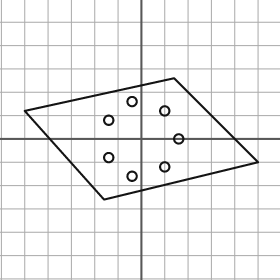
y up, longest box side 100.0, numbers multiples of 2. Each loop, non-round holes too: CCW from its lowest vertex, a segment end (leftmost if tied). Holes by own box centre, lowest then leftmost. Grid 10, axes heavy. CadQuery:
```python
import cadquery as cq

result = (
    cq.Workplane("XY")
    .moveTo(-16.0, -26.0)
    .lineTo(50.0, -10.0)
    .lineTo(14.0, 26.0)
    .lineTo(-50.0, 12.0)
    .close()
    .moveTo(-4.0, -16.0)
    .circle(2.0)
    .moveTo(10.0, -12.0)
    .circle(2.0)
    .moveTo(-14.0, -8.0)
    .circle(2.0)
    .moveTo(16.0, 0.0)
    .circle(2.0)
    .moveTo(-14.0, 8.0)
    .circle(2.0)
    .moveTo(10.0, 12.0)
    .circle(2.0)
    .moveTo(-4.0, 16.0)
    .circle(2.0)
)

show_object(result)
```